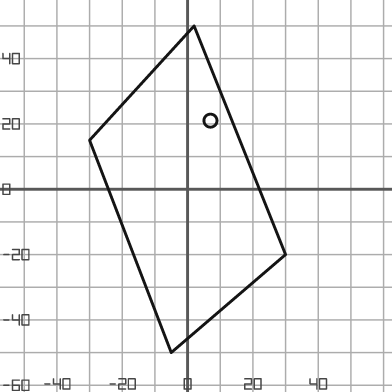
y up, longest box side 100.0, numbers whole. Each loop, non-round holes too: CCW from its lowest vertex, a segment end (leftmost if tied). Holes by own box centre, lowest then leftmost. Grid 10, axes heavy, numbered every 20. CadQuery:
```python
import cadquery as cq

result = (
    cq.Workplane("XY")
    .moveTo(-5.0, -50.0)
    .lineTo(30.0, -20.0)
    .lineTo(2.0, 50.0)
    .lineTo(-30.0, 15.0)
    .close()
    .moveTo(7.0, 21.0)
    .circle(2.0)
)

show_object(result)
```